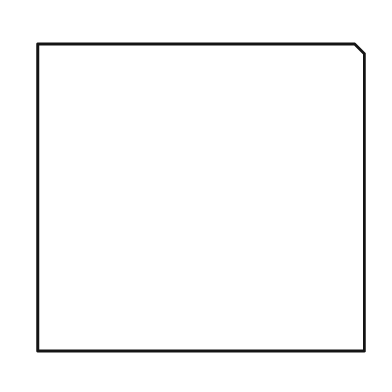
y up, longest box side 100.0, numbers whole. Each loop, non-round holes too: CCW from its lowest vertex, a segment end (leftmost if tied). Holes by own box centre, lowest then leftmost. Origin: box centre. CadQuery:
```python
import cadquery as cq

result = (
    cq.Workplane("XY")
    .moveTo(-50.0, -47.0)
    .lineTo(50.0, -47.0)
    .lineTo(50.0, 44.0)
    .lineTo(47.0, 47.0)
    .lineTo(-50.0, 47.0)
    .close()
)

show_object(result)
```